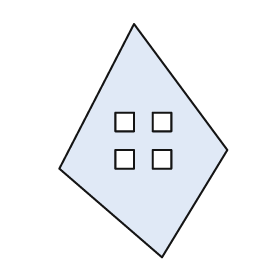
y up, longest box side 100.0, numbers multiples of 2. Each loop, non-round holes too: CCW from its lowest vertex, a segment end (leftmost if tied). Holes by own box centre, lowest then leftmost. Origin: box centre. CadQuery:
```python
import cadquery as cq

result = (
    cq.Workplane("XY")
    .moveTo(8.0, -50.0)
    .lineTo(36.0, -4.0)
    .lineTo(-4.0, 50.0)
    .lineTo(-36.0, -12.0)
    .close()
    .moveTo(-12.0, -12.0)
    .lineTo(-4.0, -12.0)
    .lineTo(-4.0, -4.0)
    .lineTo(-12.0, -4.0)
    .close()
    .moveTo(4.0, -12.0)
    .lineTo(12.0, -12.0)
    .lineTo(12.0, -4.0)
    .lineTo(4.0, -4.0)
    .close()
    .moveTo(-12.0, 4.0)
    .lineTo(-4.0, 4.0)
    .lineTo(-4.0, 12.0)
    .lineTo(-12.0, 12.0)
    .close()
    .moveTo(4.0, 4.0)
    .lineTo(12.0, 4.0)
    .lineTo(12.0, 12.0)
    .lineTo(4.0, 12.0)
    .close()
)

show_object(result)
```